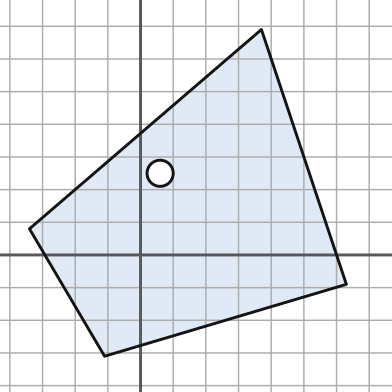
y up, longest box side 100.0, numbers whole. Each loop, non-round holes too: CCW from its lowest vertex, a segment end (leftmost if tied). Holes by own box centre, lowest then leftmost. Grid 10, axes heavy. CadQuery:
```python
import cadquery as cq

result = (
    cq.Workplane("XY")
    .moveTo(-11.0, -31.0)
    .lineTo(63.0, -9.0)
    .lineTo(37.0, 69.0)
    .lineTo(-34.0, 8.0)
    .close()
    .moveTo(6.0, 25.0)
    .circle(4.0)
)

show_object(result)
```